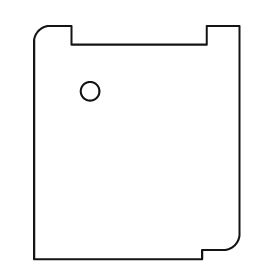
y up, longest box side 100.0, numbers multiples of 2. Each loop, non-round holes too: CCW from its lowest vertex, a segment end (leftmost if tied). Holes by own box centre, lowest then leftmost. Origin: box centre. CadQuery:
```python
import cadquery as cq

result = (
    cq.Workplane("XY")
    .moveTo(-44.0, -50.0)
    .lineTo(28.0, -50.0)
    .lineTo(28.0, -46.0)
    .lineTo(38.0, -46.0)
    .threePointArc((42.0, -44.0), (44.0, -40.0))
    .lineTo(44.0, 50.0)
    .lineTo(30.0, 50.0)
    .lineTo(30.0, 42.0)
    .lineTo(-28.0, 42.0)
    .lineTo(-28.0, 50.0)
    .lineTo(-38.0, 50.0)
    .threePointArc((-42.0, 48.0), (-44.0, 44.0))
    .close()
    .moveTo(-20.0, 22.0)
    .circle(4.0)
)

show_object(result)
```